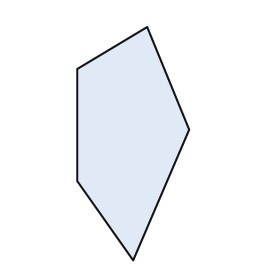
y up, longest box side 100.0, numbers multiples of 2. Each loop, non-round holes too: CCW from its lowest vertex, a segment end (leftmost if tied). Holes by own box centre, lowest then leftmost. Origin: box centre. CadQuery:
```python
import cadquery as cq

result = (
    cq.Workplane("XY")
    .moveTo(0.0, -50.0)
    .lineTo(24.0, 6.0)
    .lineTo(6.0, 50.0)
    .lineTo(-24.0, 32.0)
    .lineTo(-24.0, -16.0)
    .close()
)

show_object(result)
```